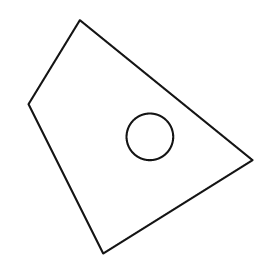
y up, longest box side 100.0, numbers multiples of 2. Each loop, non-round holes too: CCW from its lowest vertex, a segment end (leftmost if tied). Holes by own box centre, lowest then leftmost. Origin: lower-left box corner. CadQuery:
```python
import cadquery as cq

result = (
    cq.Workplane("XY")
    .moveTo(32.0, 0.0)
    .lineTo(96.0, 40.0)
    .lineTo(22.0, 100.0)
    .lineTo(0.0, 64.0)
    .close()
    .moveTo(52.0, 50.0)
    .circle(10.0)
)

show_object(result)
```